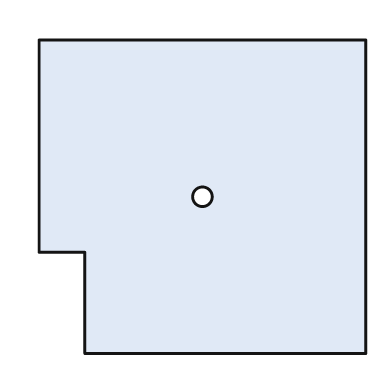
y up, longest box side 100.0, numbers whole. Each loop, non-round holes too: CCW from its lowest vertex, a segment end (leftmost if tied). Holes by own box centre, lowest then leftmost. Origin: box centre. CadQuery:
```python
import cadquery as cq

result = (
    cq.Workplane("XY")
    .moveTo(-36.0, -48.0)
    .lineTo(50.0, -48.0)
    .lineTo(50.0, 48.0)
    .lineTo(-50.0, 48.0)
    .lineTo(-50.0, -17.0)
    .lineTo(-36.0, -17.0)
    .close()
    .moveTo(0.0, 0.0)
    .circle(3.0)
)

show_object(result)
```